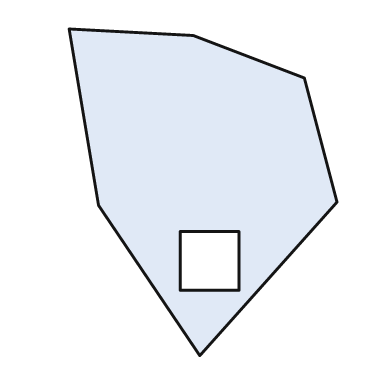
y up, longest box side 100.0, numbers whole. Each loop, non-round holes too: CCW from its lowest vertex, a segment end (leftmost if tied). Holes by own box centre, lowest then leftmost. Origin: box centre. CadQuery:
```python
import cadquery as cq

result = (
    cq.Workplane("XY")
    .moveTo(-1.0, -50.0)
    .lineTo(41.0, -3.0)
    .lineTo(31.0, 35.0)
    .lineTo(-3.0, 48.0)
    .lineTo(-41.0, 50.0)
    .lineTo(-32.0, -4.0)
    .close()
    .moveTo(-7.0, -30.0)
    .lineTo(11.0, -30.0)
    .lineTo(11.0, -12.0)
    .lineTo(-7.0, -12.0)
    .close()
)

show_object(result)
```